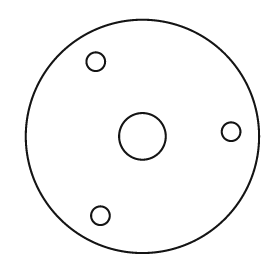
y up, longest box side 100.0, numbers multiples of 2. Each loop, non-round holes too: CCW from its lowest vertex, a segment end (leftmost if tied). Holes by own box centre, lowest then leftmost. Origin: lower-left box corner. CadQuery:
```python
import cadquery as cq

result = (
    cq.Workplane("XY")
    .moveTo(50.0, 50.0)
    .circle(50.0)
    .moveTo(32.0, 16.0)
    .circle(4.0)
    .moveTo(50.0, 50.0)
    .circle(10.0)
    .moveTo(88.0, 52.0)
    .circle(4.0)
    .moveTo(30.0, 82.0)
    .circle(4.0)
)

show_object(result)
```